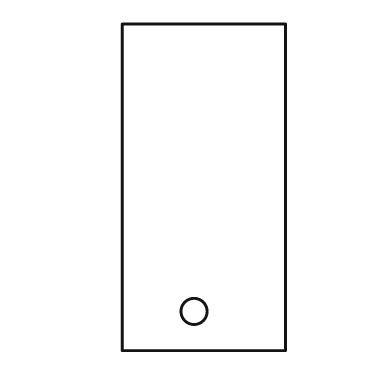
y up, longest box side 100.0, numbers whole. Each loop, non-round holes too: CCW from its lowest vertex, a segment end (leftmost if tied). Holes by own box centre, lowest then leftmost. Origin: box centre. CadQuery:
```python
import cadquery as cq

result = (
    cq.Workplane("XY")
    .moveTo(-25.0, -50.0)
    .lineTo(25.0, -50.0)
    .lineTo(25.0, 50.0)
    .lineTo(-25.0, 50.0)
    .close()
    .moveTo(-3.0, -38.0)
    .circle(4.0)
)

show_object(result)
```